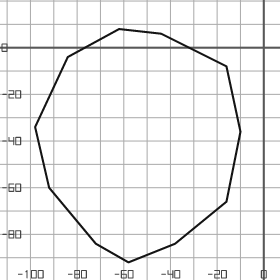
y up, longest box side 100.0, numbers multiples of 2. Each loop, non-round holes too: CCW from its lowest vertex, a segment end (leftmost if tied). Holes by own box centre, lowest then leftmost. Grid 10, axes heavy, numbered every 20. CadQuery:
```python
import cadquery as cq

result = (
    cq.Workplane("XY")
    .moveTo(-58.0, -92.0)
    .lineTo(-38.0, -84.0)
    .lineTo(-16.0, -66.0)
    .lineTo(-10.0, -36.0)
    .lineTo(-16.0, -8.0)
    .lineTo(-44.0, 6.0)
    .lineTo(-62.0, 8.0)
    .lineTo(-84.0, -4.0)
    .lineTo(-98.0, -34.0)
    .lineTo(-92.0, -60.0)
    .lineTo(-72.0, -84.0)
    .close()
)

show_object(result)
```